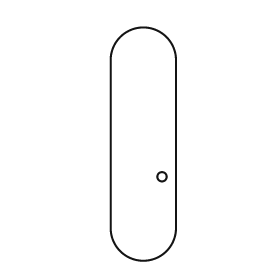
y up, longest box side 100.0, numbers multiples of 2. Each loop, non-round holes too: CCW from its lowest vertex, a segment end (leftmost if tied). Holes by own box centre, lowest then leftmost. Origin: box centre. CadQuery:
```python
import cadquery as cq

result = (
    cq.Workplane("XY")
    .moveTo(-14.0, -36.0)
    .threePointArc((0.0, -50.0), (14.0, -36.0))
    .lineTo(14.0, 36.0)
    .threePointArc((0.0, 50.0), (-14.0, 36.0))
    .close()
    .moveTo(8.0, -14.0)
    .circle(2.0)
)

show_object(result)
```